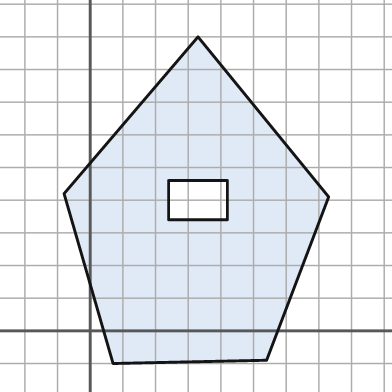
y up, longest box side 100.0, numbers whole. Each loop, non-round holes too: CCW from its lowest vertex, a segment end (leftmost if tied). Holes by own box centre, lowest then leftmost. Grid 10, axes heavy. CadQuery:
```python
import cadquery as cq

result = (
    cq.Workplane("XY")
    .moveTo(7.0, -10.0)
    .lineTo(54.0, -9.0)
    .lineTo(73.0, 41.0)
    .lineTo(33.0, 90.0)
    .lineTo(-8.0, 42.0)
    .close()
    .moveTo(24.0, 34.0)
    .lineTo(42.0, 34.0)
    .lineTo(42.0, 46.0)
    .lineTo(24.0, 46.0)
    .close()
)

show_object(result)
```